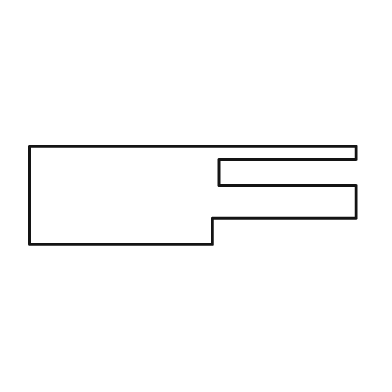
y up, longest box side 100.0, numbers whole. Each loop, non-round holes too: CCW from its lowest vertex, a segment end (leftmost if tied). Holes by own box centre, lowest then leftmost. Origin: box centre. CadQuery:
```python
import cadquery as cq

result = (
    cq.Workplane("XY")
    .moveTo(-50.0, -15.0)
    .lineTo(6.0, -15.0)
    .lineTo(6.0, -7.0)
    .lineTo(50.0, -7.0)
    .lineTo(50.0, 3.0)
    .lineTo(8.0, 3.0)
    .lineTo(8.0, 11.0)
    .lineTo(50.0, 11.0)
    .lineTo(50.0, 15.0)
    .lineTo(-50.0, 15.0)
    .close()
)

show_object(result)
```